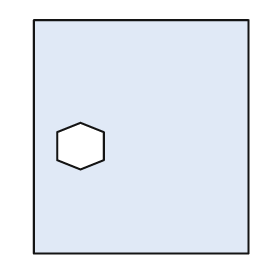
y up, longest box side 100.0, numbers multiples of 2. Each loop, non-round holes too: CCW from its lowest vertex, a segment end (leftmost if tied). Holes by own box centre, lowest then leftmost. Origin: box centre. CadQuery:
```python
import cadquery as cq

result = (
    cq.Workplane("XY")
    .moveTo(-46.0, -50.0)
    .lineTo(46.0, -50.0)
    .lineTo(46.0, 50.0)
    .lineTo(-46.0, 50.0)
    .close()
    .moveTo(-26.0, -14.0)
    .lineTo(-16.0, -10.0)
    .lineTo(-16.0, 2.0)
    .lineTo(-26.0, 6.0)
    .lineTo(-36.0, 2.0)
    .lineTo(-36.0, -10.0)
    .close()
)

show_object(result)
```